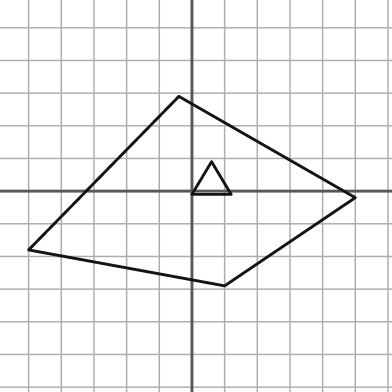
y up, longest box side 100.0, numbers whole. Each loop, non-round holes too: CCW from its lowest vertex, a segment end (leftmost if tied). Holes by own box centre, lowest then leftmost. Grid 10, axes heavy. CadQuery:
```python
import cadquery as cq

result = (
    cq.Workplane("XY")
    .moveTo(10.0, -29.0)
    .lineTo(50.0, -2.0)
    .lineTo(-4.0, 29.0)
    .lineTo(-50.0, -18.0)
    .close()
    .moveTo(0.0, -1.0)
    .lineTo(12.0, -1.0)
    .lineTo(6.0, 9.0)
    .close()
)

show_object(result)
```